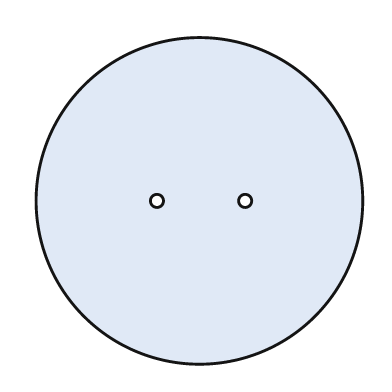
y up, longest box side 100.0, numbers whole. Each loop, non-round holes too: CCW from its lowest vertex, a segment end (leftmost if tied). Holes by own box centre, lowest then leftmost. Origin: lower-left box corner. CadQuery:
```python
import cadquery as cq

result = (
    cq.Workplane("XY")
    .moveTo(50.0, 50.0)
    .circle(50.0)
    .moveTo(37.0, 50.0)
    .circle(2.0)
    .moveTo(64.0, 50.0)
    .circle(2.0)
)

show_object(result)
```